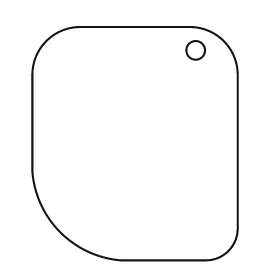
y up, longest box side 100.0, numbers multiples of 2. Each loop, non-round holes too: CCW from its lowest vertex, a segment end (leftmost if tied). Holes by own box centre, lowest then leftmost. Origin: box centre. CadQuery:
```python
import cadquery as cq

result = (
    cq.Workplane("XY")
    .moveTo(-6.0, -50.0)
    .lineTo(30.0, -50.0)
    .threePointArc((40.0, -46.0), (44.0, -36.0))
    .lineTo(44.0, 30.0)
    .threePointArc((38.0, 44.0), (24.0, 50.0))
    .lineTo(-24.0, 50.0)
    .threePointArc((-38.0, 44.0), (-44.0, 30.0))
    .lineTo(-44.0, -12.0)
    .threePointArc((-32.0, -38.0), (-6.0, -50.0))
    .close()
    .moveTo(26.0, 40.0)
    .circle(4.0)
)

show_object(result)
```